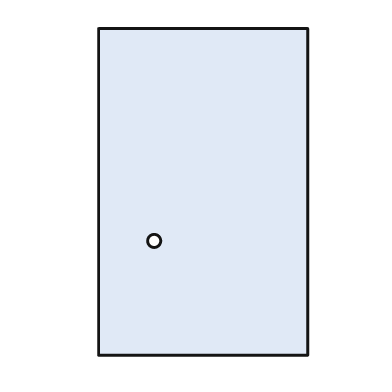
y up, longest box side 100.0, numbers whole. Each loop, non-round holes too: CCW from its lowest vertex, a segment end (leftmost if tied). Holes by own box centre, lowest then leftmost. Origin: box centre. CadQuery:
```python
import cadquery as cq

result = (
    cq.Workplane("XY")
    .moveTo(-32.0, -50.0)
    .lineTo(32.0, -50.0)
    .lineTo(32.0, 50.0)
    .lineTo(-32.0, 50.0)
    .close()
    .moveTo(-15.0, -15.0)
    .circle(2.0)
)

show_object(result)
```